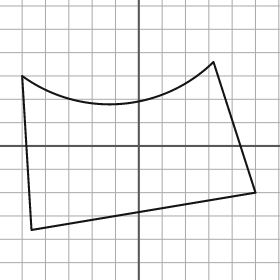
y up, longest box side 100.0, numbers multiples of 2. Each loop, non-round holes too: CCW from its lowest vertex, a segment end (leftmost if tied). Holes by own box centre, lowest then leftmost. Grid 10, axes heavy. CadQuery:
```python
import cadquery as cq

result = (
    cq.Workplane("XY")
    .moveTo(-46.0, -36.0)
    .lineTo(50.0, -20.0)
    .lineTo(32.0, 36.0)
    .threePointArc((-8.0, 18.0), (-50.0, 30.0))
    .close()
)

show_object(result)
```